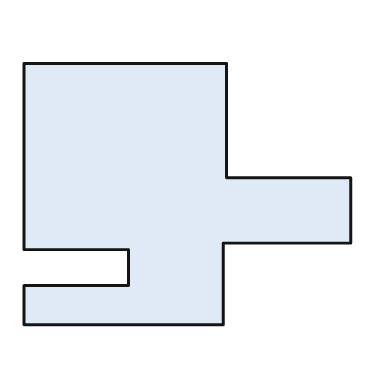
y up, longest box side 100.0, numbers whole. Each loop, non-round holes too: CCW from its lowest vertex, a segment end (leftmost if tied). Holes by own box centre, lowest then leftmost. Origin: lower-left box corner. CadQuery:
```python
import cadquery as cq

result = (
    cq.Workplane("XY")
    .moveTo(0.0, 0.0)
    .lineTo(61.0, 0.0)
    .lineTo(61.0, 25.0)
    .lineTo(100.0, 25.0)
    .lineTo(100.0, 45.0)
    .lineTo(62.0, 45.0)
    .lineTo(62.0, 80.0)
    .lineTo(0.0, 80.0)
    .lineTo(0.0, 23.0)
    .lineTo(32.0, 23.0)
    .lineTo(32.0, 12.0)
    .lineTo(0.0, 12.0)
    .close()
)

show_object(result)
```